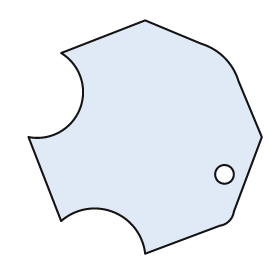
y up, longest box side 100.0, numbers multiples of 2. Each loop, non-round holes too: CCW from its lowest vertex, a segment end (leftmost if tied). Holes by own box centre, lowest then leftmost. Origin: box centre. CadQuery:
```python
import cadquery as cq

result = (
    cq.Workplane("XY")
    .moveTo(0.0, -50.0)
    .lineTo(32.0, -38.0)
    .threePointArc((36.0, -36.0), (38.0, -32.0))
    .lineTo(50.0, 0.0)
    .lineTo(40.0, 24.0)
    .threePointArc((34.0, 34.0), (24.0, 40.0))
    .lineTo(0.0, 50.0)
    .lineTo(-36.0, 36.0)
    .threePointArc((-28.0, 12.0), (-50.0, 0.0))
    .lineTo(-36.0, -36.0)
    .threePointArc((-14.0, -32.0), (0.0, -50.0))
    .close()
    .moveTo(34.0, -16.0)
    .circle(4.0)
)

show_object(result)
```